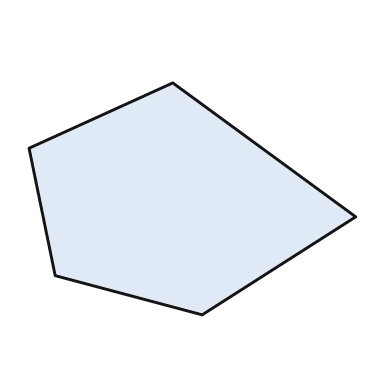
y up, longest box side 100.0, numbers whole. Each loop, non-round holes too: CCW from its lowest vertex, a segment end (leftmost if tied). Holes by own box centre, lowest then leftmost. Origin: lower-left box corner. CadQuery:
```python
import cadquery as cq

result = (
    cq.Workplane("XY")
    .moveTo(53.0, 0.0)
    .lineTo(100.0, 30.0)
    .lineTo(44.0, 71.0)
    .lineTo(0.0, 51.0)
    .lineTo(8.0, 12.0)
    .close()
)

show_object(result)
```